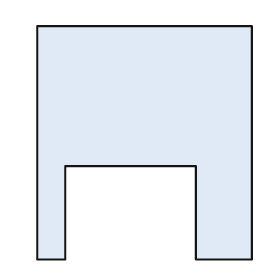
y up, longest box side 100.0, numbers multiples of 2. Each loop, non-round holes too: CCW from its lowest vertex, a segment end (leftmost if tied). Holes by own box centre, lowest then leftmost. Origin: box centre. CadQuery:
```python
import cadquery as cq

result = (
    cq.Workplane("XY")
    .moveTo(-46.0, -50.0)
    .lineTo(-34.0, -50.0)
    .lineTo(-34.0, -10.0)
    .lineTo(22.0, -10.0)
    .lineTo(22.0, -50.0)
    .lineTo(46.0, -50.0)
    .lineTo(46.0, 50.0)
    .lineTo(-46.0, 50.0)
    .close()
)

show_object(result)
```